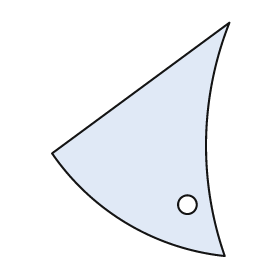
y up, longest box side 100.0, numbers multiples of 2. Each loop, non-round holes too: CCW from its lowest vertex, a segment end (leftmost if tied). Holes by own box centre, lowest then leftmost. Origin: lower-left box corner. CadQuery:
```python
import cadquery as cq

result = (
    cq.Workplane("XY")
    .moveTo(74.0, 0.0)
    .threePointArc((66.0, 50.0), (76.0, 100.0))
    .lineTo(0.0, 44.0)
    .threePointArc((32.0, 14.0), (74.0, 0.0))
    .close()
    .moveTo(58.0, 22.0)
    .circle(4.0)
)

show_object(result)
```